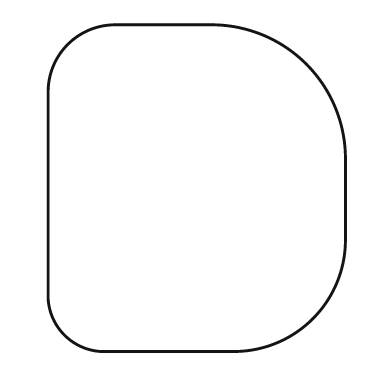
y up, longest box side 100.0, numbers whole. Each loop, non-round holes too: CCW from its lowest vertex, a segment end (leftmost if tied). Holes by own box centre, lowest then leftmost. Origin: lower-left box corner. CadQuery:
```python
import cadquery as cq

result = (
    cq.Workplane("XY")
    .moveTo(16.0, 0.0)
    .lineTo(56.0, 0.0)
    .threePointArc((81.0, 10.0), (91.0, 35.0))
    .lineTo(91.0, 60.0)
    .threePointArc((79.0, 88.0), (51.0, 100.0))
    .lineTo(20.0, 100.0)
    .threePointArc((6.0, 94.0), (0.0, 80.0))
    .lineTo(0.0, 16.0)
    .threePointArc((5.0, 5.0), (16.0, 0.0))
    .close()
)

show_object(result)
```